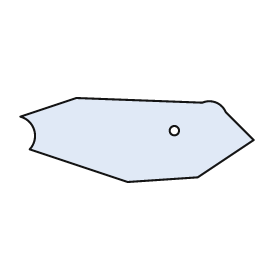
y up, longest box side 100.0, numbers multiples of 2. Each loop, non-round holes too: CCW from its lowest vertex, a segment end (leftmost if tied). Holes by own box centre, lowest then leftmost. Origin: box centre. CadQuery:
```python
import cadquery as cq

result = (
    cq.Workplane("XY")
    .moveTo(-4.0, -18.0)
    .lineTo(26.0, -16.0)
    .lineTo(50.0, 0.0)
    .lineTo(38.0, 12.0)
    .threePointArc((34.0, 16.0), (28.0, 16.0))
    .lineTo(-26.0, 18.0)
    .lineTo(-50.0, 10.0)
    .threePointArc((-44.0, 4.0), (-46.0, -4.0))
    .close()
    .moveTo(16.0, 4.0)
    .circle(2.0)
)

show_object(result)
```